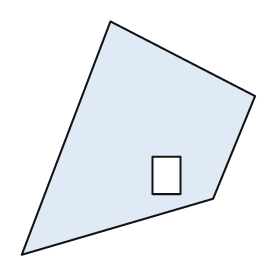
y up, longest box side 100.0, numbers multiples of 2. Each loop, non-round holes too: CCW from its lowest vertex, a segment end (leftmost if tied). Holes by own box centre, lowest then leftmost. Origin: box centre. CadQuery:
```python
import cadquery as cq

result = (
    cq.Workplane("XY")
    .moveTo(-50.0, -50.0)
    .lineTo(32.0, -26.0)
    .lineTo(50.0, 18.0)
    .lineTo(-12.0, 50.0)
    .close()
    .moveTo(6.0, -24.0)
    .lineTo(18.0, -24.0)
    .lineTo(18.0, -8.0)
    .lineTo(6.0, -8.0)
    .close()
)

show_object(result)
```